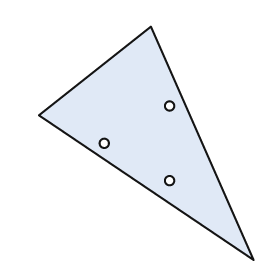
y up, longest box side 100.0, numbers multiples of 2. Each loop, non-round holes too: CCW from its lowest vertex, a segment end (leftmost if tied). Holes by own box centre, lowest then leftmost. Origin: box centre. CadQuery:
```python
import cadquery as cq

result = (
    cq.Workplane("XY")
    .moveTo(46.0, -50.0)
    .lineTo(2.0, 50.0)
    .lineTo(-46.0, 12.0)
    .close()
    .moveTo(10.0, -16.0)
    .circle(2.0)
    .moveTo(-18.0, 0.0)
    .circle(2.0)
    .moveTo(10.0, 16.0)
    .circle(2.0)
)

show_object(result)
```